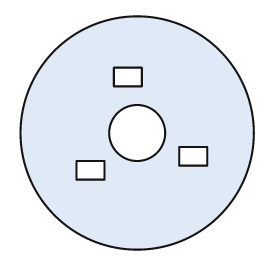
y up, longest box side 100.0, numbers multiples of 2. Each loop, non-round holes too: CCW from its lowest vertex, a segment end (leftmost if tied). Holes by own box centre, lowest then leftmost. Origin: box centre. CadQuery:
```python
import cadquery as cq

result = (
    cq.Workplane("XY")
    .moveTo(0.0, 0.0)
    .circle(50.0)
    .moveTo(-26.0, -20.0)
    .lineTo(-14.0, -20.0)
    .lineTo(-14.0, -12.0)
    .lineTo(-26.0, -12.0)
    .close()
    .moveTo(18.0, -14.0)
    .lineTo(30.0, -14.0)
    .lineTo(30.0, -6.0)
    .lineTo(18.0, -6.0)
    .close()
    .moveTo(0.0, 0.0)
    .circle(12.0)
    .moveTo(-10.0, 20.0)
    .lineTo(2.0, 20.0)
    .lineTo(2.0, 28.0)
    .lineTo(-10.0, 28.0)
    .close()
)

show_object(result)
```